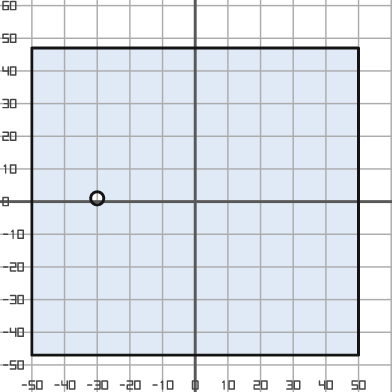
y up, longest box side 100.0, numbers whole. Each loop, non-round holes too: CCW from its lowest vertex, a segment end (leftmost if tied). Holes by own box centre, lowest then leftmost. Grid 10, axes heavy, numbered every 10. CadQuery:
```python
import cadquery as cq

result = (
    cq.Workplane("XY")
    .moveTo(-50.0, -47.0)
    .lineTo(50.0, -47.0)
    .lineTo(50.0, 47.0)
    .lineTo(-50.0, 47.0)
    .close()
    .moveTo(-30.0, 1.0)
    .circle(2.0)
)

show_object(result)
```